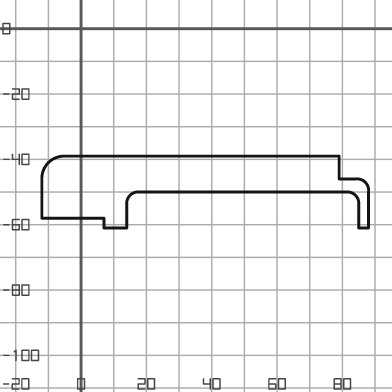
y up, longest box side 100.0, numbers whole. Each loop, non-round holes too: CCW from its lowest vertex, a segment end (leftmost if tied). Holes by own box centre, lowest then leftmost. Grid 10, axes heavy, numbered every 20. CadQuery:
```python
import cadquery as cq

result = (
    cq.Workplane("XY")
    .moveTo(7.0, -61.0)
    .lineTo(14.0, -61.0)
    .lineTo(14.0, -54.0)
    .threePointArc((15.0, -51.0), (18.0, -50.0))
    .lineTo(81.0, -50.0)
    .threePointArc((84.0, -51.0), (85.0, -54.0))
    .lineTo(85.0, -61.0)
    .lineTo(88.0, -61.0)
    .lineTo(88.0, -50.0)
    .threePointArc((87.0, -47.0), (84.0, -46.0))
    .lineTo(79.0, -46.0)
    .lineTo(79.0, -39.0)
    .lineTo(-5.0, -39.0)
    .threePointArc((-10.0, -41.0), (-12.0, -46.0))
    .lineTo(-12.0, -58.0)
    .lineTo(7.0, -58.0)
    .close()
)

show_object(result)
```